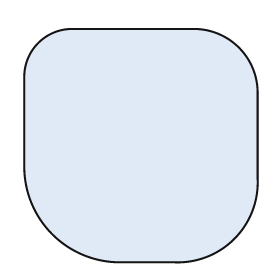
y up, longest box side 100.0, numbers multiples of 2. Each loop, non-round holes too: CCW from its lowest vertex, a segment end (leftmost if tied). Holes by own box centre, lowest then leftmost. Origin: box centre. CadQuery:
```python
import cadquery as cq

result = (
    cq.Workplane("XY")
    .moveTo(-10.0, -50.0)
    .lineTo(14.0, -50.0)
    .threePointArc((40.0, -40.0), (50.0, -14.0))
    .lineTo(50.0, 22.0)
    .threePointArc((42.0, 42.0), (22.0, 50.0))
    .lineTo(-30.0, 50.0)
    .threePointArc((-44.0, 44.0), (-50.0, 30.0))
    .lineTo(-50.0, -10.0)
    .threePointArc((-38.0, -38.0), (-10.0, -50.0))
    .close()
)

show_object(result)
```